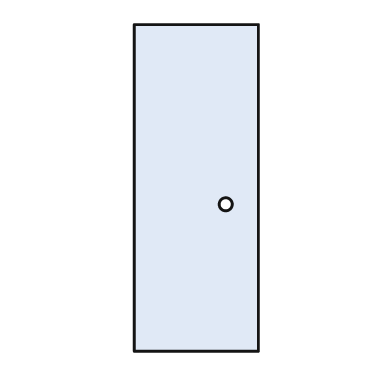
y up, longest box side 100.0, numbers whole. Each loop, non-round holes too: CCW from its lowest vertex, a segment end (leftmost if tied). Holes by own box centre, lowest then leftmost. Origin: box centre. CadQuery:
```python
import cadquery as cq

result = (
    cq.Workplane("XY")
    .moveTo(-19.0, -50.0)
    .lineTo(19.0, -50.0)
    .lineTo(19.0, 50.0)
    .lineTo(-19.0, 50.0)
    .close()
    .moveTo(9.0, -5.0)
    .circle(2.0)
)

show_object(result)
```